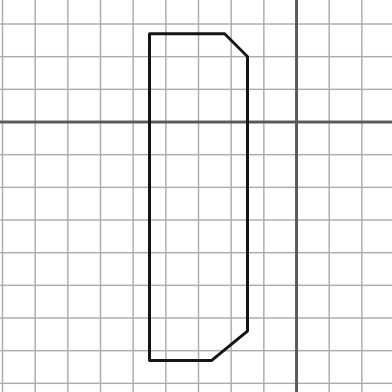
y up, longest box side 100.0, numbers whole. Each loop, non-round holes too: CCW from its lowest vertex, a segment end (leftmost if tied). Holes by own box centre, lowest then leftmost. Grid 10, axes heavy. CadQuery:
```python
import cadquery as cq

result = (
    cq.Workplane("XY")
    .moveTo(-45.0, -73.0)
    .lineTo(-26.0, -73.0)
    .lineTo(-15.0, -64.0)
    .lineTo(-15.0, 20.0)
    .lineTo(-22.0, 27.0)
    .lineTo(-45.0, 27.0)
    .close()
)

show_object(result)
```